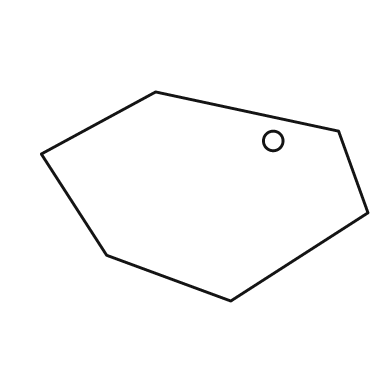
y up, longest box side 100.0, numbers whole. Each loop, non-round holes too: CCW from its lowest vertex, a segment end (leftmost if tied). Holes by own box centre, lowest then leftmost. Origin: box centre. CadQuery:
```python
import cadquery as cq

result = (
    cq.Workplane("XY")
    .moveTo(8.0, -32.0)
    .lineTo(50.0, -5.0)
    .lineTo(41.0, 20.0)
    .lineTo(-15.0, 32.0)
    .lineTo(-50.0, 13.0)
    .lineTo(-30.0, -18.0)
    .close()
    .moveTo(21.0, 17.0)
    .circle(3.0)
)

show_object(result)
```